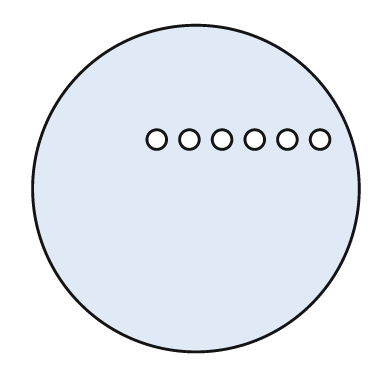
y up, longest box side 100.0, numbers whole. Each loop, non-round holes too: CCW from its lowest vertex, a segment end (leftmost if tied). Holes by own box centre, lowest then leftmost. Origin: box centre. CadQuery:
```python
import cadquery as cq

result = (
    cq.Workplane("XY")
    .moveTo(0.0, 0.0)
    .circle(50.0)
    .moveTo(-12.0, 15.0)
    .circle(3.0)
    .moveTo(-2.0, 15.0)
    .circle(3.0)
    .moveTo(8.0, 15.0)
    .circle(3.0)
    .moveTo(18.0, 15.0)
    .circle(3.0)
    .moveTo(28.0, 15.0)
    .circle(3.0)
    .moveTo(38.0, 15.0)
    .circle(3.0)
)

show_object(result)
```